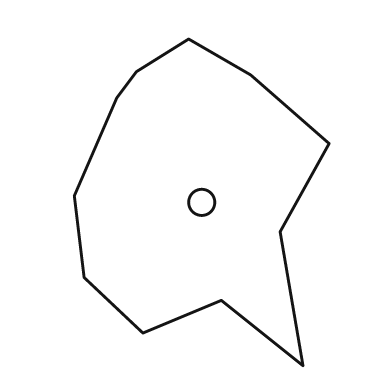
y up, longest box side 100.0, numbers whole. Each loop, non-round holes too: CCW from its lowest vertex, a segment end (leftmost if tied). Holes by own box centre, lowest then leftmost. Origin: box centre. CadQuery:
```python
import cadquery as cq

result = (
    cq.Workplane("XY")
    .moveTo(31.0, -50.0)
    .lineTo(24.0, -9.0)
    .lineTo(39.0, 18.0)
    .lineTo(15.0, 39.0)
    .lineTo(-4.0, 50.0)
    .lineTo(-20.0, 40.0)
    .lineTo(-26.0, 32.0)
    .lineTo(-39.0, 2.0)
    .lineTo(-36.0, -23.0)
    .lineTo(-18.0, -40.0)
    .lineTo(6.0, -30.0)
    .close()
    .moveTo(0.0, 0.0)
    .circle(4.0)
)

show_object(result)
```